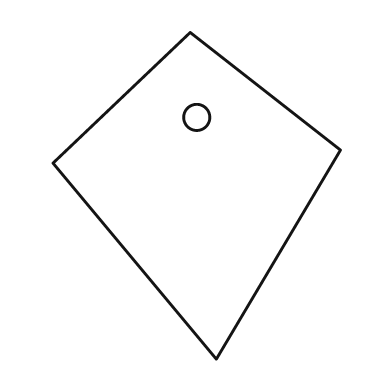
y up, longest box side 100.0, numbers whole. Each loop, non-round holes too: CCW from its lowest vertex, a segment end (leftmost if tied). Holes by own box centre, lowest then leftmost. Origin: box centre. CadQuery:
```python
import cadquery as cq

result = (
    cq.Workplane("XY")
    .moveTo(6.0, -50.0)
    .lineTo(44.0, 14.0)
    .lineTo(-2.0, 50.0)
    .lineTo(-44.0, 10.0)
    .close()
    .moveTo(0.0, 24.0)
    .circle(4.0)
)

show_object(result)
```